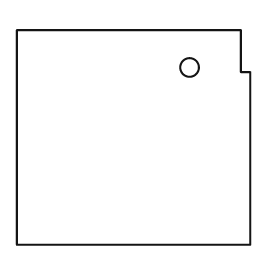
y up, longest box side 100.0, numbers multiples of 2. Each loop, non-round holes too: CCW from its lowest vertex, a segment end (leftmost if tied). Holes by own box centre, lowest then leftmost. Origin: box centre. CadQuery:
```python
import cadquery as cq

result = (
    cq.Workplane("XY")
    .moveTo(-50.0, -46.0)
    .lineTo(50.0, -46.0)
    .lineTo(50.0, 28.0)
    .lineTo(46.0, 28.0)
    .lineTo(46.0, 46.0)
    .lineTo(-50.0, 46.0)
    .close()
    .moveTo(24.0, 30.0)
    .circle(4.0)
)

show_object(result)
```